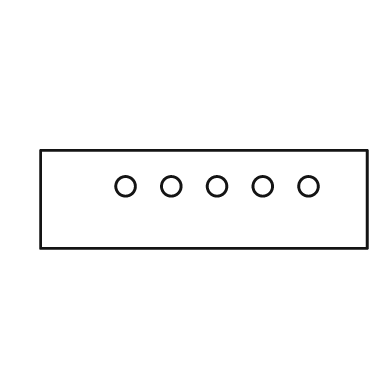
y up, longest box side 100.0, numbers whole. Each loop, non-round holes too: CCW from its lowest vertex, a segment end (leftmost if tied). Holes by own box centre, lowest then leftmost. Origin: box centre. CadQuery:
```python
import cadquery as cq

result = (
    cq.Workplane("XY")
    .moveTo(-50.0, -15.0)
    .lineTo(50.0, -15.0)
    .lineTo(50.0, 15.0)
    .lineTo(-50.0, 15.0)
    .close()
    .moveTo(-24.0, 4.0)
    .circle(3.0)
    .moveTo(-10.0, 4.0)
    .circle(3.0)
    .moveTo(4.0, 4.0)
    .circle(3.0)
    .moveTo(18.0, 4.0)
    .circle(3.0)
    .moveTo(32.0, 4.0)
    .circle(3.0)
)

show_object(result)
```